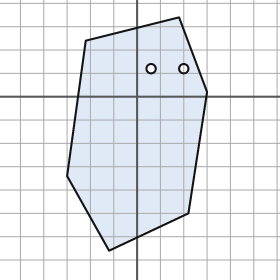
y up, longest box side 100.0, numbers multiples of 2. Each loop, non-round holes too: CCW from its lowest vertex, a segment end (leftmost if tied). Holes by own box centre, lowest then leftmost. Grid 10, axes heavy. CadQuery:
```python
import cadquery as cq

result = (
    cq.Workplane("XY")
    .moveTo(-12.0, -66.0)
    .lineTo(22.0, -50.0)
    .lineTo(30.0, 2.0)
    .lineTo(18.0, 34.0)
    .lineTo(-22.0, 24.0)
    .lineTo(-30.0, -34.0)
    .close()
    .moveTo(6.0, 12.0)
    .circle(2.0)
    .moveTo(20.0, 12.0)
    .circle(2.0)
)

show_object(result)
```